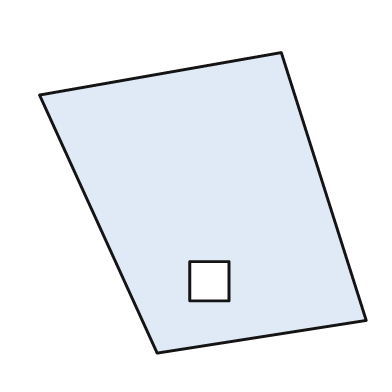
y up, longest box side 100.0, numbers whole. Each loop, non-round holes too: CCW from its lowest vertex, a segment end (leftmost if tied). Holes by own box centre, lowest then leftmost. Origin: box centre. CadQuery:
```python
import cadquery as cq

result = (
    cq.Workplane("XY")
    .moveTo(-14.0, -46.0)
    .lineTo(50.0, -36.0)
    .lineTo(24.0, 46.0)
    .lineTo(-50.0, 33.0)
    .close()
    .moveTo(-4.0, -30.0)
    .lineTo(8.0, -30.0)
    .lineTo(8.0, -18.0)
    .lineTo(-4.0, -18.0)
    .close()
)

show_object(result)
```